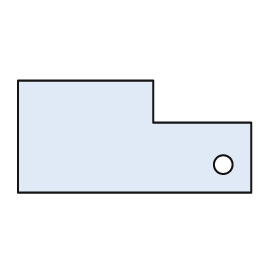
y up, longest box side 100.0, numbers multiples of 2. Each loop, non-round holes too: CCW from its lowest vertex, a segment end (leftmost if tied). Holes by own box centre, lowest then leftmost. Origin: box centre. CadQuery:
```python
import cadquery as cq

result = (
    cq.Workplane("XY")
    .moveTo(-50.0, -24.0)
    .lineTo(50.0, -24.0)
    .lineTo(50.0, 6.0)
    .lineTo(8.0, 6.0)
    .lineTo(8.0, 24.0)
    .lineTo(-50.0, 24.0)
    .close()
    .moveTo(38.0, -12.0)
    .circle(4.0)
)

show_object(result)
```